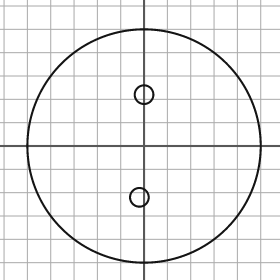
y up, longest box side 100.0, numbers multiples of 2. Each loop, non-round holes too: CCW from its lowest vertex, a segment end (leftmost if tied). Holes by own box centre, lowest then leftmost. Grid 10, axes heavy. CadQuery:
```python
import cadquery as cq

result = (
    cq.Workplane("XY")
    .moveTo(0.0, 0.0)
    .circle(50.0)
    .moveTo(-2.0, -22.0)
    .circle(4.0)
    .moveTo(0.0, 22.0)
    .circle(4.0)
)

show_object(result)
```